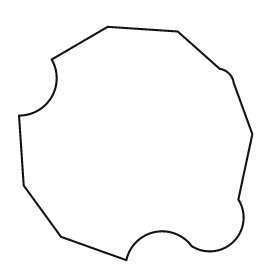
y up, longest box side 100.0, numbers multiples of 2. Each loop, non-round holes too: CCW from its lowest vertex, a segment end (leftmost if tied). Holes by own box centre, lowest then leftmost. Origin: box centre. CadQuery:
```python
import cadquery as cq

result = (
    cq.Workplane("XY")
    .moveTo(-4.0, -50.0)
    .threePointArc((8.0, -38.0), (24.0, -44.0))
    .threePointArc((42.0, -42.0), (44.0, -24.0))
    .lineTo(50.0, 4.0)
    .lineTo(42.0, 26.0)
    .threePointArc((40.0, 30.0), (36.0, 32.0))
    .lineTo(18.0, 48.0)
    .lineTo(-12.0, 50.0)
    .lineTo(-36.0, 36.0)
    .threePointArc((-36.0, 20.0), (-50.0, 12.0))
    .lineTo(-48.0, -18.0)
    .lineTo(-32.0, -40.0)
    .close()
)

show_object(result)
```